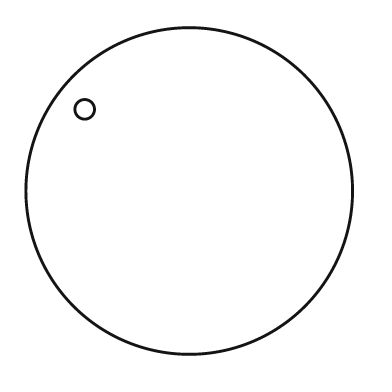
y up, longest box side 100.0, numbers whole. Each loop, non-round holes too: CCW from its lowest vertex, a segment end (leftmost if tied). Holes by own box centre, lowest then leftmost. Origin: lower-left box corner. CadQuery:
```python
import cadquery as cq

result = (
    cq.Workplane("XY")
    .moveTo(50.0, 50.0)
    .circle(50.0)
    .moveTo(18.0, 75.0)
    .circle(3.0)
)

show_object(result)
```